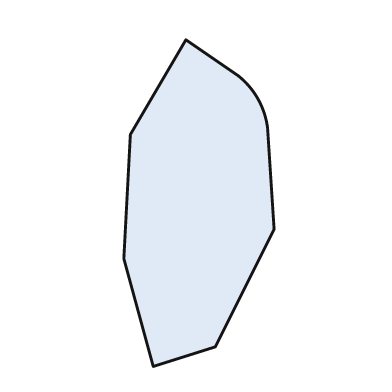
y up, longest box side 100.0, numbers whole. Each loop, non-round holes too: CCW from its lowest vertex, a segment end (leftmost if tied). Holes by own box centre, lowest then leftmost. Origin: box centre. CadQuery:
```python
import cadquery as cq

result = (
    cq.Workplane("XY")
    .moveTo(-14.0, -50.0)
    .lineTo(5.0, -44.0)
    .lineTo(23.0, -8.0)
    .lineTo(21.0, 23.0)
    .threePointArc((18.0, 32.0), (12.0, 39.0))
    .lineTo(-4.0, 50.0)
    .lineTo(-21.0, 21.0)
    .lineTo(-23.0, -17.0)
    .close()
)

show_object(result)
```